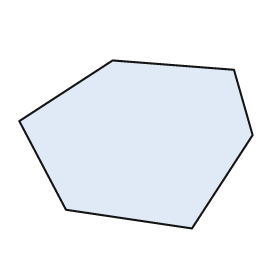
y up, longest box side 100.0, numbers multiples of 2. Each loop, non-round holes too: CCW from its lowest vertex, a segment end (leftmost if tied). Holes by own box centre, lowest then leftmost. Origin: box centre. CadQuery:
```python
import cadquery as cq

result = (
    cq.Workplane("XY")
    .moveTo(24.0, -36.0)
    .lineTo(50.0, 4.0)
    .lineTo(42.0, 32.0)
    .lineTo(-10.0, 36.0)
    .lineTo(-50.0, 10.0)
    .lineTo(-30.0, -28.0)
    .close()
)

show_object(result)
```